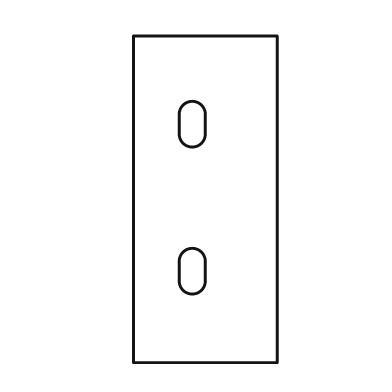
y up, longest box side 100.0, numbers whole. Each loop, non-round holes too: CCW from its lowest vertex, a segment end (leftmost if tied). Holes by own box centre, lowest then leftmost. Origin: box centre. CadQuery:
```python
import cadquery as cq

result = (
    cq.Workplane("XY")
    .moveTo(-22.0, -50.0)
    .lineTo(22.0, -50.0)
    .lineTo(22.0, 50.0)
    .lineTo(-22.0, 50.0)
    .close()
    .moveTo(-8.0, -25.0)
    .threePointArc((-4.0, -29.0), (0.0, -25.0))
    .lineTo(0.0, -19.0)
    .threePointArc((-4.0, -15.0), (-8.0, -19.0))
    .close()
    .moveTo(-8.0, 20.0)
    .threePointArc((-4.0, 16.0), (0.0, 20.0))
    .lineTo(0.0, 26.0)
    .threePointArc((-4.0, 30.0), (-8.0, 26.0))
    .close()
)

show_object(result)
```